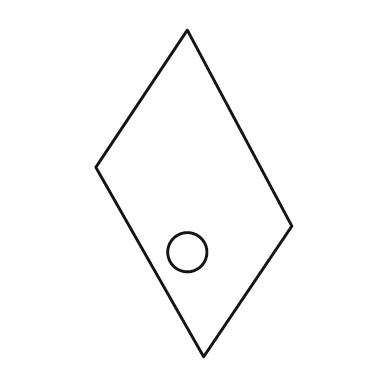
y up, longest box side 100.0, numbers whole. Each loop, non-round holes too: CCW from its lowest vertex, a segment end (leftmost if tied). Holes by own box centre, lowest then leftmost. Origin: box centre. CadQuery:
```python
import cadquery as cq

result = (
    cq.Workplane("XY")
    .moveTo(3.0, -50.0)
    .lineTo(30.0, -10.0)
    .lineTo(-2.0, 50.0)
    .lineTo(-30.0, 8.0)
    .close()
    .moveTo(-2.0, -18.0)
    .circle(6.0)
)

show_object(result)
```